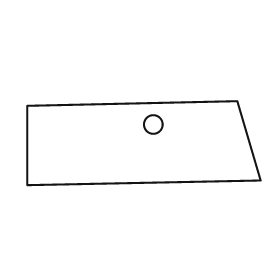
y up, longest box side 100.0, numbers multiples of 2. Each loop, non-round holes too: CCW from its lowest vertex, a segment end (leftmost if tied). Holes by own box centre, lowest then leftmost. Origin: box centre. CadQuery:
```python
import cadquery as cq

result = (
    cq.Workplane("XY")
    .moveTo(-50.0, -18.0)
    .lineTo(50.0, -16.0)
    .lineTo(40.0, 18.0)
    .lineTo(-50.0, 16.0)
    .close()
    .moveTo(4.0, 8.0)
    .circle(4.0)
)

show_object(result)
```